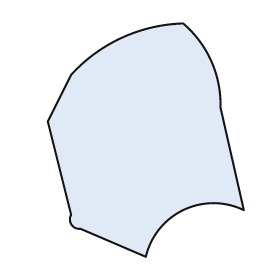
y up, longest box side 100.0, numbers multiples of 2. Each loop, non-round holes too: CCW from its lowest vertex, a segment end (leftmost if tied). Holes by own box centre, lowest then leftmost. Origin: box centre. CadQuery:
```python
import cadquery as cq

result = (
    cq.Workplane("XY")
    .moveTo(0.0, -50.0)
    .threePointArc((16.0, -30.0), (42.0, -30.0))
    .lineTo(32.0, 14.0)
    .threePointArc((28.0, 34.0), (16.0, 50.0))
    .threePointArc((-10.0, 44.0), (-32.0, 28.0))
    .lineTo(-42.0, 8.0)
    .lineTo(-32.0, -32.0)
    .threePointArc((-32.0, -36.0), (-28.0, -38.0))
    .close()
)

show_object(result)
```